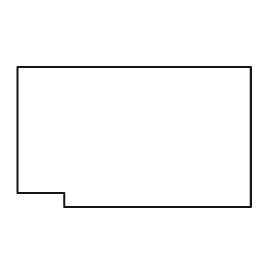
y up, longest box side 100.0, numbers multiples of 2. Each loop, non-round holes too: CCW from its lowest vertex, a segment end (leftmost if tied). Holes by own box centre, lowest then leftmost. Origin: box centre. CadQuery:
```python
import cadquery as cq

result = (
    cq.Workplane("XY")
    .moveTo(-30.0, -30.0)
    .lineTo(50.0, -30.0)
    .lineTo(50.0, 30.0)
    .lineTo(-50.0, 30.0)
    .lineTo(-50.0, -24.0)
    .lineTo(-30.0, -24.0)
    .close()
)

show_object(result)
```